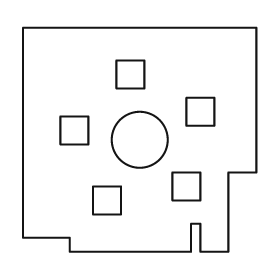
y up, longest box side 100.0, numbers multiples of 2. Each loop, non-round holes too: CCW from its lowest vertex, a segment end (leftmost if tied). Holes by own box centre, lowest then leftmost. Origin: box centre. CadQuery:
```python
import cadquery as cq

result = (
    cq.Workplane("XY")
    .moveTo(-30.0, -48.0)
    .lineTo(22.0, -48.0)
    .lineTo(22.0, -36.0)
    .lineTo(26.0, -36.0)
    .lineTo(26.0, -48.0)
    .lineTo(38.0, -48.0)
    .lineTo(38.0, -14.0)
    .lineTo(50.0, -14.0)
    .lineTo(50.0, 48.0)
    .lineTo(-50.0, 48.0)
    .lineTo(-50.0, -42.0)
    .lineTo(-30.0, -42.0)
    .close()
    .moveTo(-20.0, -32.0)
    .lineTo(-8.0, -32.0)
    .lineTo(-8.0, -20.0)
    .lineTo(-20.0, -20.0)
    .close()
    .moveTo(14.0, -26.0)
    .lineTo(26.0, -26.0)
    .lineTo(26.0, -14.0)
    .lineTo(14.0, -14.0)
    .close()
    .moveTo(0.0, 0.0)
    .circle(12.0)
    .moveTo(-34.0, -2.0)
    .lineTo(-22.0, -2.0)
    .lineTo(-22.0, 10.0)
    .lineTo(-34.0, 10.0)
    .close()
    .moveTo(20.0, 6.0)
    .lineTo(32.0, 6.0)
    .lineTo(32.0, 18.0)
    .lineTo(20.0, 18.0)
    .close()
    .moveTo(-10.0, 22.0)
    .lineTo(2.0, 22.0)
    .lineTo(2.0, 34.0)
    .lineTo(-10.0, 34.0)
    .close()
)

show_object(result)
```